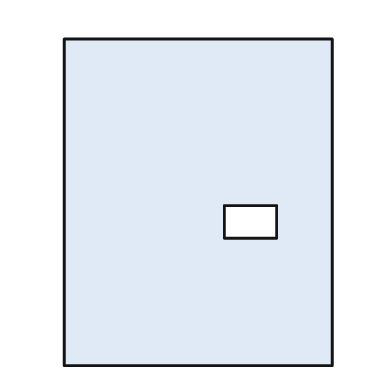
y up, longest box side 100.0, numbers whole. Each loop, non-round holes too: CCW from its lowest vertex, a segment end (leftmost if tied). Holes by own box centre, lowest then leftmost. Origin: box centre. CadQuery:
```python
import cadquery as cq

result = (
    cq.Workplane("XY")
    .moveTo(-41.0, -50.0)
    .lineTo(41.0, -50.0)
    .lineTo(41.0, 50.0)
    .lineTo(-41.0, 50.0)
    .close()
    .moveTo(8.0, -11.0)
    .lineTo(24.0, -11.0)
    .lineTo(24.0, -1.0)
    .lineTo(8.0, -1.0)
    .close()
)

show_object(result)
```